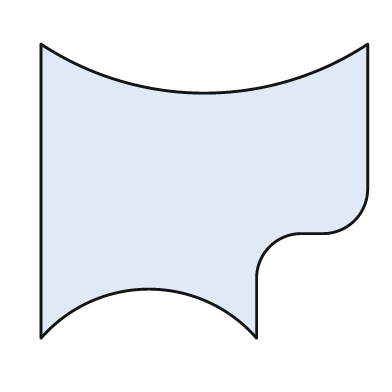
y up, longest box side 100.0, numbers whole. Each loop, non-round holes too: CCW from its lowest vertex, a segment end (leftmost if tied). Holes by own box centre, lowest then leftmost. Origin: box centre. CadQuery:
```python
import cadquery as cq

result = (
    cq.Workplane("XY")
    .moveTo(-50.0, -45.0)
    .threePointArc((-17.0, -30.0), (16.0, -45.0))
    .lineTo(16.0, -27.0)
    .threePointArc((20.0, -17.0), (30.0, -13.0))
    .lineTo(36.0, -13.0)
    .threePointArc((46.0, -9.0), (50.0, 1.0))
    .lineTo(50.0, 45.0)
    .threePointArc((0.0, 30.0), (-50.0, 45.0))
    .close()
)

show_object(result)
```